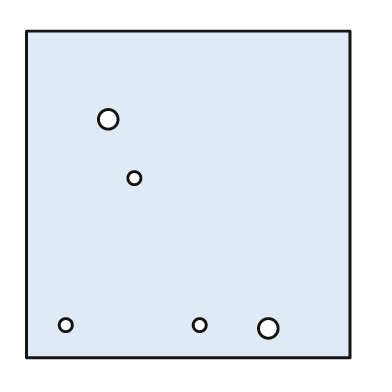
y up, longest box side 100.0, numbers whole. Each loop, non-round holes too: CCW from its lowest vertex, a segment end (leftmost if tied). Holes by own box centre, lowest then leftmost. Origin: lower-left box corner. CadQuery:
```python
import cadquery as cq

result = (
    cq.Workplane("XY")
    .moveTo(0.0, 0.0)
    .lineTo(99.0, 0.0)
    .lineTo(99.0, 100.0)
    .lineTo(0.0, 100.0)
    .close()
    .moveTo(74.0, 9.0)
    .circle(3.0)
    .moveTo(12.0, 10.0)
    .circle(2.0)
    .moveTo(53.0, 10.0)
    .circle(2.0)
    .moveTo(33.0, 55.0)
    .circle(2.0)
    .moveTo(25.0, 73.0)
    .circle(3.0)
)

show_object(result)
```